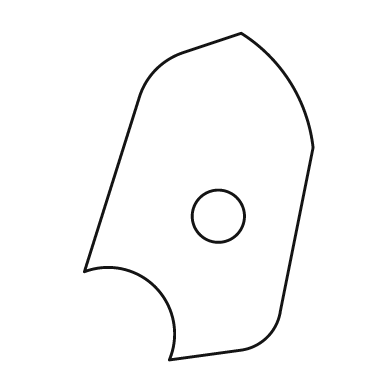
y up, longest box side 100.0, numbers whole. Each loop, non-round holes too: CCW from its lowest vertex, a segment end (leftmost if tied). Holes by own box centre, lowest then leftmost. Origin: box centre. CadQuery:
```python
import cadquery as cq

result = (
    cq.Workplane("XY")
    .moveTo(-9.0, -50.0)
    .lineTo(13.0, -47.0)
    .threePointArc((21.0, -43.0), (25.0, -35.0))
    .lineTo(35.0, 15.0)
    .threePointArc((28.0, 35.0), (13.0, 50.0))
    .lineTo(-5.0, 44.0)
    .threePointArc((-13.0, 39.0), (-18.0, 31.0))
    .lineTo(-35.0, -23.0)
    .threePointArc((-13.0, -28.0), (-9.0, -50.0))
    .close()
    .moveTo(6.0, -6.0)
    .circle(8.0)
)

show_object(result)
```